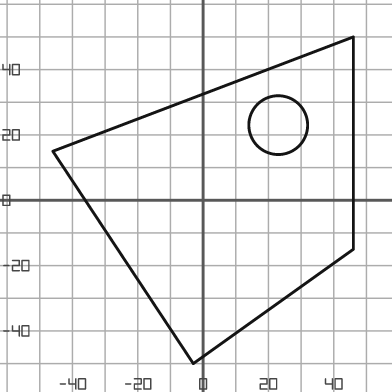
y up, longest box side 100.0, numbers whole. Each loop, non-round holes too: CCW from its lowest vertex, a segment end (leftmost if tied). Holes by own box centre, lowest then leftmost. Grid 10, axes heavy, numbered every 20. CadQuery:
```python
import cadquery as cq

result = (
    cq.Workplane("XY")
    .moveTo(-3.0, -50.0)
    .lineTo(46.0, -15.0)
    .lineTo(46.0, 50.0)
    .lineTo(-46.0, 15.0)
    .close()
    .moveTo(23.0, 23.0)
    .circle(9.0)
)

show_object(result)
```